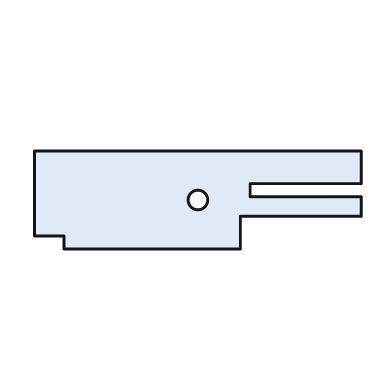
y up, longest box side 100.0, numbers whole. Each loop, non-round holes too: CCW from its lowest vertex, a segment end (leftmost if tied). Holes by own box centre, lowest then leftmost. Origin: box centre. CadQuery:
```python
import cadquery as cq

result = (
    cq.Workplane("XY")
    .moveTo(-41.0, -15.0)
    .lineTo(13.0, -15.0)
    .lineTo(13.0, -5.0)
    .lineTo(50.0, -5.0)
    .lineTo(50.0, 1.0)
    .lineTo(16.0, 1.0)
    .lineTo(16.0, 5.0)
    .lineTo(50.0, 5.0)
    .lineTo(50.0, 15.0)
    .lineTo(-50.0, 15.0)
    .lineTo(-50.0, -11.0)
    .lineTo(-41.0, -11.0)
    .close()
    .moveTo(0.0, 0.0)
    .circle(3.0)
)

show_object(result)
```